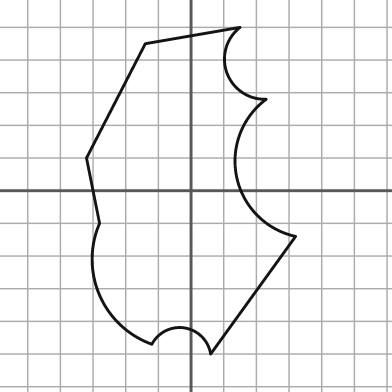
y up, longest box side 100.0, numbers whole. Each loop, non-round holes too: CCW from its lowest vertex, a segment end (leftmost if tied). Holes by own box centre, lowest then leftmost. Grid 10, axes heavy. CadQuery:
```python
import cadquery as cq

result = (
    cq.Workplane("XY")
    .moveTo(6.0, -50.0)
    .lineTo(32.0, -14.0)
    .threePointArc((14.0, 4.0), (23.0, 28.0))
    .threePointArc((11.0, 36.0), (15.0, 50.0))
    .lineTo(-14.0, 45.0)
    .lineTo(-32.0, 10.0)
    .lineTo(-28.0, -10.0)
    .threePointArc((-28.0, -32.0), (-12.0, -47.0))
    .threePointArc((-2.0, -42.0), (6.0, -50.0))
    .close()
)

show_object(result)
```